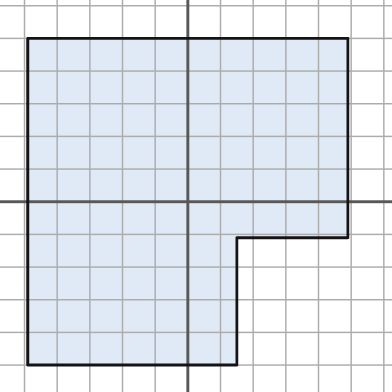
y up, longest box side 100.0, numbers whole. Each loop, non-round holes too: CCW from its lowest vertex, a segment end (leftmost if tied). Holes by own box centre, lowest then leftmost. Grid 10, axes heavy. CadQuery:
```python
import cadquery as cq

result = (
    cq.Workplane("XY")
    .moveTo(-49.0, -50.0)
    .lineTo(15.0, -50.0)
    .lineTo(15.0, -11.0)
    .lineTo(49.0, -11.0)
    .lineTo(49.0, 50.0)
    .lineTo(-49.0, 50.0)
    .close()
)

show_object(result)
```